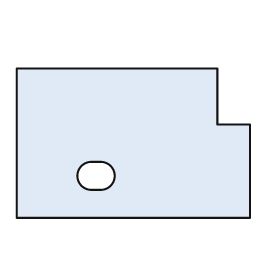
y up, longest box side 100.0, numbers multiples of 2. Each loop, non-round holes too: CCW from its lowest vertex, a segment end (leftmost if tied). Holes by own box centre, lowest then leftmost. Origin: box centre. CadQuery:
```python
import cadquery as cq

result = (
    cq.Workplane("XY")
    .moveTo(-50.0, -32.0)
    .lineTo(50.0, -32.0)
    .lineTo(50.0, 8.0)
    .lineTo(36.0, 8.0)
    .lineTo(36.0, 32.0)
    .lineTo(-50.0, 32.0)
    .close()
    .moveTo(-18.0, -20.0)
    .lineTo(-14.0, -20.0)
    .threePointArc((-8.0, -14.0), (-14.0, -8.0))
    .lineTo(-18.0, -8.0)
    .threePointArc((-24.0, -14.0), (-18.0, -20.0))
    .close()
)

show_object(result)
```